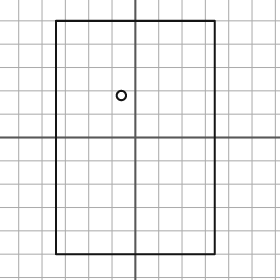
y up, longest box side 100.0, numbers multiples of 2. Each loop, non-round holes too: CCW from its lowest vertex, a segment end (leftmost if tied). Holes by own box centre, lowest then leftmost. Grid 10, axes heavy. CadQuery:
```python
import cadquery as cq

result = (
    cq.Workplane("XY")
    .moveTo(-34.0, -50.0)
    .lineTo(34.0, -50.0)
    .lineTo(34.0, 50.0)
    .lineTo(-34.0, 50.0)
    .close()
    .moveTo(-6.0, 18.0)
    .circle(2.0)
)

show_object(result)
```